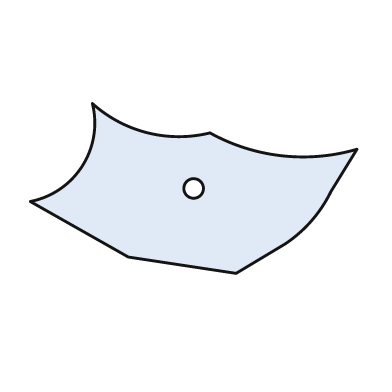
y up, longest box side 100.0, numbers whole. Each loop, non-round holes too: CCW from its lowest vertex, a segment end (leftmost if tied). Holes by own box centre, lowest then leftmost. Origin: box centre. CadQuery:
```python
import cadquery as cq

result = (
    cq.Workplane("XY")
    .moveTo(13.0, -26.0)
    .lineTo(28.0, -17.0)
    .threePointArc((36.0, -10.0), (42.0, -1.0))
    .lineTo(50.0, 12.0)
    .threePointArc((27.0, 10.0), (5.0, 17.0))
    .threePointArc((-14.0, 17.0), (-31.0, 26.0))
    .threePointArc((-34.0, 7.0), (-50.0, -4.0))
    .lineTo(-20.0, -21.0)
    .close()
    .moveTo(0.0, 0.0)
    .circle(3.0)
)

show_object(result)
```